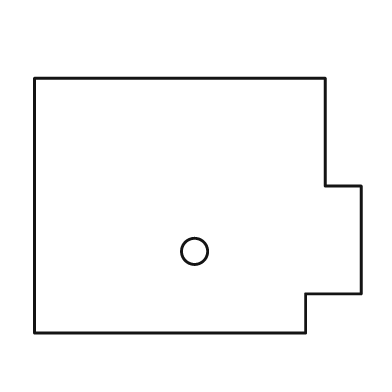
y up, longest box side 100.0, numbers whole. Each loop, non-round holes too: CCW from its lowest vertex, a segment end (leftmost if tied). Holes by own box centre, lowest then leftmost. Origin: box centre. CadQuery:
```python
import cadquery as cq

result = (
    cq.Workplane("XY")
    .moveTo(-50.0, -39.0)
    .lineTo(33.0, -39.0)
    .lineTo(33.0, -27.0)
    .lineTo(50.0, -27.0)
    .lineTo(50.0, 6.0)
    .lineTo(39.0, 6.0)
    .lineTo(39.0, 39.0)
    .lineTo(-50.0, 39.0)
    .close()
    .moveTo(-1.0, -14.0)
    .circle(4.0)
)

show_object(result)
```